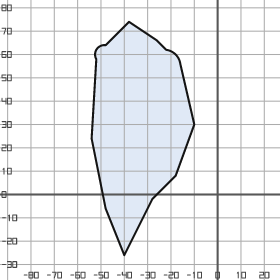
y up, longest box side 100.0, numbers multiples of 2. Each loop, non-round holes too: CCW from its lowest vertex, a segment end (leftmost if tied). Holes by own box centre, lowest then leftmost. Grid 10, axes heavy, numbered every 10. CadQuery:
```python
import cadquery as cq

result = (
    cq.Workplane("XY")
    .moveTo(-40.0, -26.0)
    .lineTo(-28.0, -2.0)
    .lineTo(-18.0, 8.0)
    .lineTo(-10.0, 30.0)
    .lineTo(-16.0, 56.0)
    .threePointArc((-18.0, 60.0), (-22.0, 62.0))
    .lineTo(-26.0, 66.0)
    .lineTo(-38.0, 74.0)
    .lineTo(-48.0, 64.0)
    .threePointArc((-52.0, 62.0), (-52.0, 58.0))
    .lineTo(-54.0, 24.0)
    .lineTo(-48.0, -6.0)
    .close()
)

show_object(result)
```